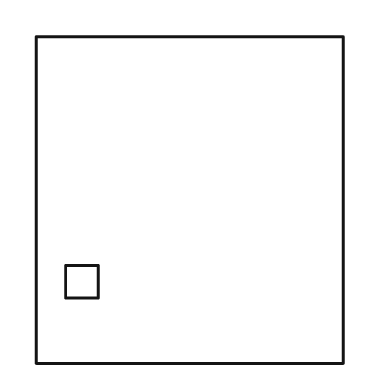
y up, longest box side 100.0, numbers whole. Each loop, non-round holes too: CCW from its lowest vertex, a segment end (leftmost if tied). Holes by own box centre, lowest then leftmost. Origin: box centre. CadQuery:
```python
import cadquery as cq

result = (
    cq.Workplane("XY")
    .moveTo(-47.0, -50.0)
    .lineTo(47.0, -50.0)
    .lineTo(47.0, 50.0)
    .lineTo(-47.0, 50.0)
    .close()
    .moveTo(-38.0, -30.0)
    .lineTo(-28.0, -30.0)
    .lineTo(-28.0, -20.0)
    .lineTo(-38.0, -20.0)
    .close()
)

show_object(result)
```